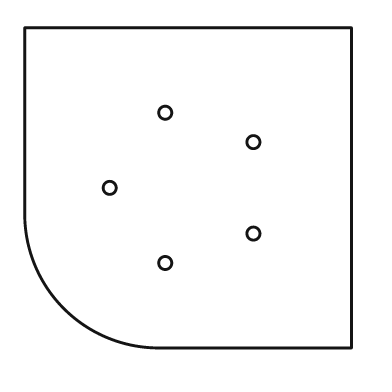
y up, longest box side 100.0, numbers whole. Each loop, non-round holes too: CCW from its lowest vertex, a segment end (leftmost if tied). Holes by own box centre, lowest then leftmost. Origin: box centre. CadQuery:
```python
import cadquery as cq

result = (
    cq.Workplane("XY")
    .moveTo(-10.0, -49.0)
    .lineTo(50.0, -49.0)
    .lineTo(50.0, 49.0)
    .lineTo(-50.0, 49.0)
    .lineTo(-50.0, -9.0)
    .threePointArc((-38.0, -37.0), (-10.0, -49.0))
    .close()
    .moveTo(-7.0, -23.0)
    .circle(2.0)
    .moveTo(20.0, -14.0)
    .circle(2.0)
    .moveTo(-24.0, 0.0)
    .circle(2.0)
    .moveTo(20.0, 14.0)
    .circle(2.0)
    .moveTo(-7.0, 23.0)
    .circle(2.0)
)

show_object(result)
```